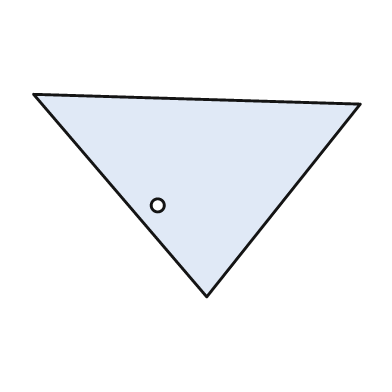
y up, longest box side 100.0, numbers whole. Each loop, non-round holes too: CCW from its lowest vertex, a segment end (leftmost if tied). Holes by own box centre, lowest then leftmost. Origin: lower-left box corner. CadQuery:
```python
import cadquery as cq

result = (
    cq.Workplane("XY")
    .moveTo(53.0, 0.0)
    .lineTo(100.0, 59.0)
    .lineTo(0.0, 62.0)
    .close()
    .moveTo(38.0, 28.0)
    .circle(2.0)
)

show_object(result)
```